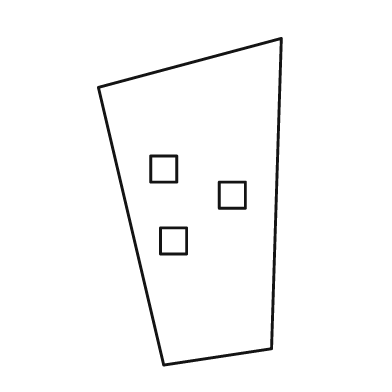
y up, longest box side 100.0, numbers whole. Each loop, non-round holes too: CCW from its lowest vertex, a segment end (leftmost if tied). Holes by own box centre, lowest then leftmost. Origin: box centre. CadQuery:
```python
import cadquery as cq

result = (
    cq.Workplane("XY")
    .moveTo(-8.0, -50.0)
    .lineTo(25.0, -45.0)
    .lineTo(28.0, 50.0)
    .lineTo(-28.0, 35.0)
    .close()
    .moveTo(-9.0, -16.0)
    .lineTo(-1.0, -16.0)
    .lineTo(-1.0, -8.0)
    .lineTo(-9.0, -8.0)
    .close()
    .moveTo(9.0, -2.0)
    .lineTo(17.0, -2.0)
    .lineTo(17.0, 6.0)
    .lineTo(9.0, 6.0)
    .close()
    .moveTo(-12.0, 6.0)
    .lineTo(-4.0, 6.0)
    .lineTo(-4.0, 14.0)
    .lineTo(-12.0, 14.0)
    .close()
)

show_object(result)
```